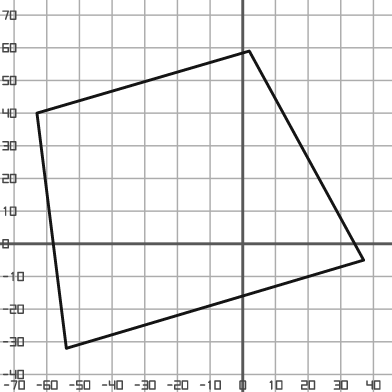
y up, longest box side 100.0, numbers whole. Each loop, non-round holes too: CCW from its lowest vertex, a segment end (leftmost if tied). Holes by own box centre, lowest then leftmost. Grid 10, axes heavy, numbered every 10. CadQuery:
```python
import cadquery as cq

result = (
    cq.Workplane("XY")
    .moveTo(-54.0, -32.0)
    .lineTo(37.0, -5.0)
    .lineTo(2.0, 59.0)
    .lineTo(-63.0, 40.0)
    .close()
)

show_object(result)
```